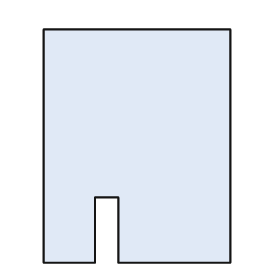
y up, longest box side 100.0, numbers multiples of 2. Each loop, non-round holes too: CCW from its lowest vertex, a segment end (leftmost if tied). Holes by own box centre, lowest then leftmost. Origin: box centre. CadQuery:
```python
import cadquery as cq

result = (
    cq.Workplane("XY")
    .moveTo(-40.0, -50.0)
    .lineTo(-18.0, -50.0)
    .lineTo(-18.0, -22.0)
    .lineTo(-8.0, -22.0)
    .lineTo(-8.0, -50.0)
    .lineTo(40.0, -50.0)
    .lineTo(40.0, 50.0)
    .lineTo(-40.0, 50.0)
    .close()
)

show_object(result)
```